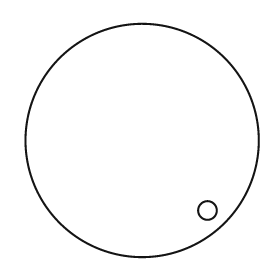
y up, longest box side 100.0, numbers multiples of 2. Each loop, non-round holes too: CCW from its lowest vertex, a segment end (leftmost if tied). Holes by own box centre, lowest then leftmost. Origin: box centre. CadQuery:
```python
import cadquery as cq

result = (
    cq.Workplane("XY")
    .moveTo(0.0, 0.0)
    .circle(50.0)
    .moveTo(28.0, -30.0)
    .circle(4.0)
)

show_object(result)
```